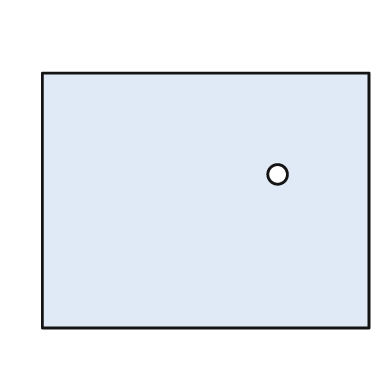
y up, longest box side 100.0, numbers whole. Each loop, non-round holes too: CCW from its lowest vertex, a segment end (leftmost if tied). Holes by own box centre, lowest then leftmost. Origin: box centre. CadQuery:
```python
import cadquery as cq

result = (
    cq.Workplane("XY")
    .moveTo(-50.0, -39.0)
    .lineTo(50.0, -39.0)
    .lineTo(50.0, 39.0)
    .lineTo(-50.0, 39.0)
    .close()
    .moveTo(22.0, 8.0)
    .circle(3.0)
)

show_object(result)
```